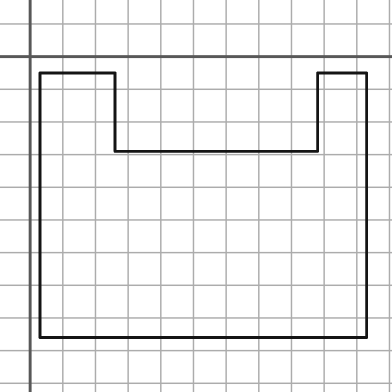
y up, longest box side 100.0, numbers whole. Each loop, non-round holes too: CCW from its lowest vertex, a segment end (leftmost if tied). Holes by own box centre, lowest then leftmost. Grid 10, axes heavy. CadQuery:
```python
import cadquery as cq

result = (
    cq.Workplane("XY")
    .moveTo(3.0, -86.0)
    .lineTo(103.0, -86.0)
    .lineTo(103.0, -5.0)
    .lineTo(88.0, -5.0)
    .lineTo(88.0, -29.0)
    .lineTo(26.0, -29.0)
    .lineTo(26.0, -5.0)
    .lineTo(3.0, -5.0)
    .close()
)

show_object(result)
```